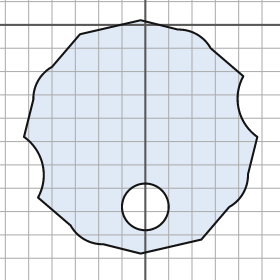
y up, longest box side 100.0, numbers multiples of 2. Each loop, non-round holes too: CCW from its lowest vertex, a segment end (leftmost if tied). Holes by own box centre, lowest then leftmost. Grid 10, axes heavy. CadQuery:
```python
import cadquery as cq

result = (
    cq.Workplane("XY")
    .moveTo(-2.0, -98.0)
    .lineTo(24.0, -92.0)
    .lineTo(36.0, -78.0)
    .threePointArc((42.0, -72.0), (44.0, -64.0))
    .lineTo(48.0, -48.0)
    .threePointArc((40.0, -36.0), (42.0, -22.0))
    .lineTo(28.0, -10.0)
    .threePointArc((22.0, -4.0), (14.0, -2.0))
    .lineTo(-2.0, 2.0)
    .lineTo(-28.0, -4.0)
    .lineTo(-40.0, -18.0)
    .threePointArc((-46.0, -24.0), (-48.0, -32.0))
    .lineTo(-52.0, -48.0)
    .threePointArc((-44.0, -60.0), (-46.0, -74.0))
    .lineTo(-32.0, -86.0)
    .threePointArc((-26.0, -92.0), (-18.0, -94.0))
    .close()
    .moveTo(0.0, -78.0)
    .circle(10.0)
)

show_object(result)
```